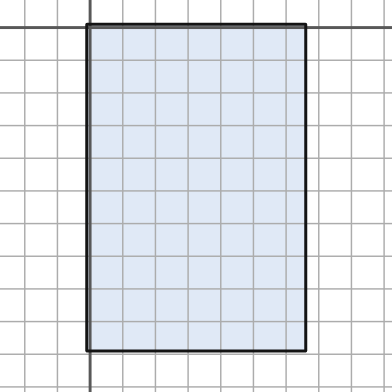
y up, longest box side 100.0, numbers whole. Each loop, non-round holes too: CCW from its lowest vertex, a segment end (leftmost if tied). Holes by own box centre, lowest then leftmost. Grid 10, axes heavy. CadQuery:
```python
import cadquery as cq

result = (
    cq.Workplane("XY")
    .moveTo(-1.0, -99.0)
    .lineTo(66.0, -99.0)
    .lineTo(66.0, 1.0)
    .lineTo(-1.0, 1.0)
    .close()
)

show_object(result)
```